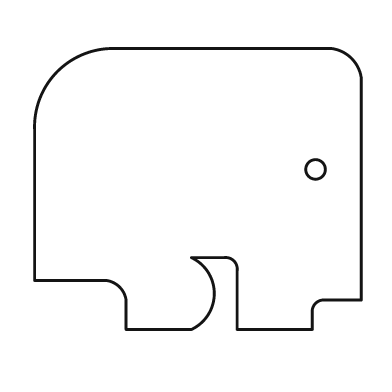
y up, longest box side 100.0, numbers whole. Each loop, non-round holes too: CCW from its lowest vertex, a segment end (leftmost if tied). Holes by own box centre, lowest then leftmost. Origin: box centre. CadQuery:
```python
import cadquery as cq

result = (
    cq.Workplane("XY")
    .moveTo(-22.0, -43.0)
    .lineTo(-2.0, -43.0)
    .threePointArc((5.0, -32.0), (-2.0, -21.0))
    .lineTo(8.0, -21.0)
    .threePointArc((11.0, -22.0), (12.0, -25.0))
    .lineTo(12.0, -43.0)
    .lineTo(35.0, -43.0)
    .lineTo(35.0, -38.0)
    .threePointArc((36.0, -35.0), (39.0, -34.0))
    .lineTo(50.0, -34.0)
    .lineTo(50.0, 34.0)
    .threePointArc((47.0, 40.0), (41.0, 43.0))
    .lineTo(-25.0, 43.0)
    .threePointArc((-43.0, 36.0), (-50.0, 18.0))
    .lineTo(-50.0, -28.0)
    .lineTo(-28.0, -28.0)
    .threePointArc((-24.0, -30.0), (-22.0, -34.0))
    .close()
    .moveTo(36.0, 6.0)
    .circle(3.0)
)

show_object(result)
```